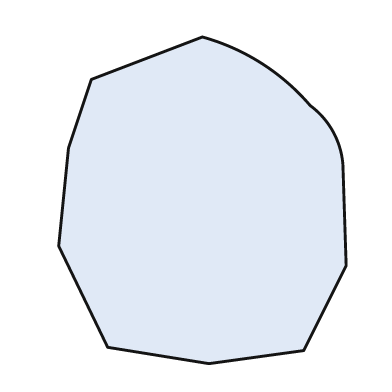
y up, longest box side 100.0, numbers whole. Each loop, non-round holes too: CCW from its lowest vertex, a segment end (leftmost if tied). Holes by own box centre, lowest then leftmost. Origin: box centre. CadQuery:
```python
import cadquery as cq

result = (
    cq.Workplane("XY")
    .moveTo(2.0, -50.0)
    .lineTo(31.0, -46.0)
    .lineTo(44.0, -20.0)
    .lineTo(43.0, 11.0)
    .threePointArc((40.0, 21.0), (33.0, 29.0))
    .threePointArc((18.0, 42.0), (0.0, 50.0))
    .lineTo(-34.0, 37.0)
    .lineTo(-41.0, 16.0)
    .lineTo(-44.0, -14.0)
    .lineTo(-29.0, -45.0)
    .close()
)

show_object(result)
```